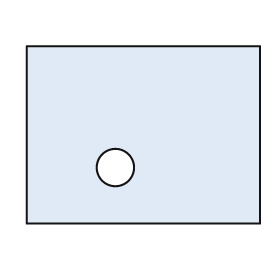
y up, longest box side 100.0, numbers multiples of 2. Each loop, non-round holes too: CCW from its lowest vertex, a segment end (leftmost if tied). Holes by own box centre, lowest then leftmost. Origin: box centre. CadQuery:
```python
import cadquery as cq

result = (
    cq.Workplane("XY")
    .moveTo(-50.0, -38.0)
    .lineTo(50.0, -38.0)
    .lineTo(50.0, 38.0)
    .lineTo(-50.0, 38.0)
    .close()
    .moveTo(-12.0, -14.0)
    .circle(8.0)
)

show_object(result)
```